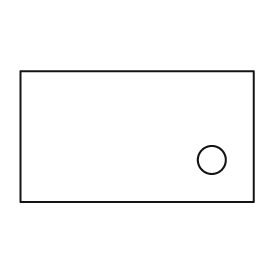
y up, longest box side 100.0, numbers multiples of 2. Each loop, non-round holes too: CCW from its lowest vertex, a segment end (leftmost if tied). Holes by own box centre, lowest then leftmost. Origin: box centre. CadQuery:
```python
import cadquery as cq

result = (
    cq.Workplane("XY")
    .moveTo(-50.0, -28.0)
    .lineTo(50.0, -28.0)
    .lineTo(50.0, 28.0)
    .lineTo(-50.0, 28.0)
    .close()
    .moveTo(32.0, -10.0)
    .circle(6.0)
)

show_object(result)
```